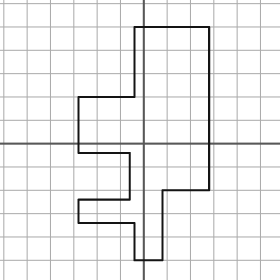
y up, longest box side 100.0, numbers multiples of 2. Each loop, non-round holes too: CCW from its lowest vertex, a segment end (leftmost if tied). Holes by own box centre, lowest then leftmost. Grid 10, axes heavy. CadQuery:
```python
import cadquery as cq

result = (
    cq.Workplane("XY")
    .moveTo(-4.0, -50.0)
    .lineTo(8.0, -50.0)
    .lineTo(8.0, -20.0)
    .lineTo(28.0, -20.0)
    .lineTo(28.0, 50.0)
    .lineTo(-4.0, 50.0)
    .lineTo(-4.0, 20.0)
    .lineTo(-28.0, 20.0)
    .lineTo(-28.0, -4.0)
    .lineTo(-6.0, -4.0)
    .lineTo(-6.0, -24.0)
    .lineTo(-28.0, -24.0)
    .lineTo(-28.0, -34.0)
    .lineTo(-4.0, -34.0)
    .close()
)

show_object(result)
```